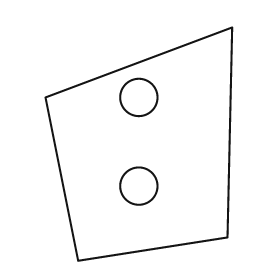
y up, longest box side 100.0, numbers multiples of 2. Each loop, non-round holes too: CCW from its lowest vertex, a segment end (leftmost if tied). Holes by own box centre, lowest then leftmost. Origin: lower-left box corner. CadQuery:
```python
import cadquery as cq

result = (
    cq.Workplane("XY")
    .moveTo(14.0, 0.0)
    .lineTo(78.0, 10.0)
    .lineTo(80.0, 100.0)
    .lineTo(0.0, 70.0)
    .close()
    .moveTo(40.0, 32.0)
    .circle(8.0)
    .moveTo(40.0, 70.0)
    .circle(8.0)
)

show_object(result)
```